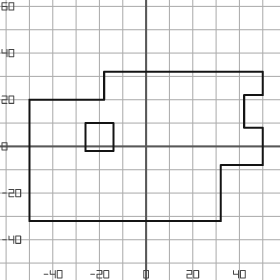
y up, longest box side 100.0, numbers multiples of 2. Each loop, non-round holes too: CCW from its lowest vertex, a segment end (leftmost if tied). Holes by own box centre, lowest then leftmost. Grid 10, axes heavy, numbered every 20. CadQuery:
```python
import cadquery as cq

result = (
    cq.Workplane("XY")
    .moveTo(-50.0, -32.0)
    .lineTo(32.0, -32.0)
    .lineTo(32.0, -8.0)
    .lineTo(50.0, -8.0)
    .lineTo(50.0, 8.0)
    .lineTo(42.0, 8.0)
    .lineTo(42.0, 22.0)
    .lineTo(50.0, 22.0)
    .lineTo(50.0, 32.0)
    .lineTo(-18.0, 32.0)
    .lineTo(-18.0, 20.0)
    .lineTo(-50.0, 20.0)
    .close()
    .moveTo(-26.0, -2.0)
    .lineTo(-14.0, -2.0)
    .lineTo(-14.0, 10.0)
    .lineTo(-26.0, 10.0)
    .close()
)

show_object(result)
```